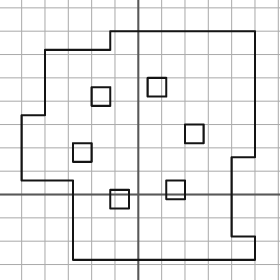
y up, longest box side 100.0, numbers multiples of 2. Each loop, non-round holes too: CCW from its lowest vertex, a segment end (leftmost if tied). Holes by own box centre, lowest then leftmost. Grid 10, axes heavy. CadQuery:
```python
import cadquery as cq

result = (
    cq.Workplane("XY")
    .moveTo(-28.0, -28.0)
    .lineTo(50.0, -28.0)
    .lineTo(50.0, -18.0)
    .lineTo(40.0, -18.0)
    .lineTo(40.0, 16.0)
    .lineTo(50.0, 16.0)
    .lineTo(50.0, 70.0)
    .lineTo(-12.0, 70.0)
    .lineTo(-12.0, 62.0)
    .lineTo(-40.0, 62.0)
    .lineTo(-40.0, 34.0)
    .lineTo(-50.0, 34.0)
    .lineTo(-50.0, 6.0)
    .lineTo(-28.0, 6.0)
    .close()
    .moveTo(-12.0, -6.0)
    .lineTo(-4.0, -6.0)
    .lineTo(-4.0, 2.0)
    .lineTo(-12.0, 2.0)
    .close()
    .moveTo(12.0, -2.0)
    .lineTo(20.0, -2.0)
    .lineTo(20.0, 6.0)
    .lineTo(12.0, 6.0)
    .close()
    .moveTo(-28.0, 14.0)
    .lineTo(-20.0, 14.0)
    .lineTo(-20.0, 22.0)
    .lineTo(-28.0, 22.0)
    .close()
    .moveTo(20.0, 22.0)
    .lineTo(28.0, 22.0)
    .lineTo(28.0, 30.0)
    .lineTo(20.0, 30.0)
    .close()
    .moveTo(-20.0, 38.0)
    .lineTo(-12.0, 38.0)
    .lineTo(-12.0, 46.0)
    .lineTo(-20.0, 46.0)
    .close()
    .moveTo(4.0, 42.0)
    .lineTo(12.0, 42.0)
    .lineTo(12.0, 50.0)
    .lineTo(4.0, 50.0)
    .close()
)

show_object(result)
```